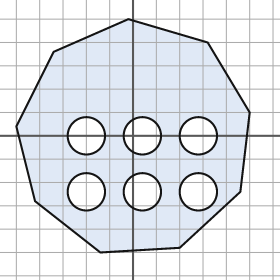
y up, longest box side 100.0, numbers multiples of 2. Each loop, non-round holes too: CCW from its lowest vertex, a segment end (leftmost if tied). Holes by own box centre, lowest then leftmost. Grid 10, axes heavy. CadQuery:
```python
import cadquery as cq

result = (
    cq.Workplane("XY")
    .moveTo(-14.0, -50.0)
    .lineTo(20.0, -48.0)
    .lineTo(46.0, -24.0)
    .lineTo(50.0, 10.0)
    .lineTo(32.0, 40.0)
    .lineTo(-2.0, 50.0)
    .lineTo(-34.0, 36.0)
    .lineTo(-50.0, 4.0)
    .lineTo(-42.0, -28.0)
    .close()
    .moveTo(-20.0, -24.0)
    .circle(8.0)
    .moveTo(4.0, -24.0)
    .circle(8.0)
    .moveTo(28.0, -24.0)
    .circle(8.0)
    .moveTo(-20.0, 0.0)
    .circle(8.0)
    .moveTo(4.0, 0.0)
    .circle(8.0)
    .moveTo(28.0, 0.0)
    .circle(8.0)
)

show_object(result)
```